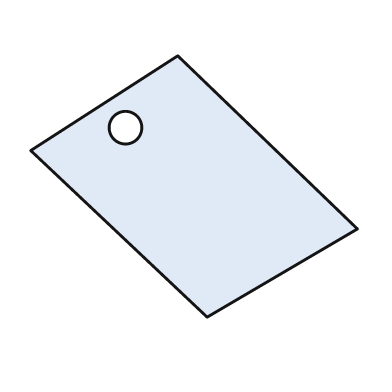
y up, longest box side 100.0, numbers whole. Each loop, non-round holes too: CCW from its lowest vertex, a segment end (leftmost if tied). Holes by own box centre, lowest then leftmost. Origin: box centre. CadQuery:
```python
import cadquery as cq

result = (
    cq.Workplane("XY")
    .moveTo(4.0, -40.0)
    .lineTo(50.0, -13.0)
    .lineTo(-5.0, 40.0)
    .lineTo(-50.0, 11.0)
    .close()
    .moveTo(-21.0, 18.0)
    .circle(5.0)
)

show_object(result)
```